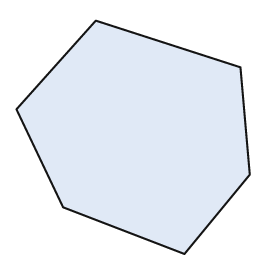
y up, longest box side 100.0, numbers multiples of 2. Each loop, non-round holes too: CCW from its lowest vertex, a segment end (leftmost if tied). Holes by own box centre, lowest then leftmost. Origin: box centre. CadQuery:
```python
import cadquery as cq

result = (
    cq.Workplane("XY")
    .moveTo(22.0, -50.0)
    .lineTo(50.0, -16.0)
    .lineTo(46.0, 30.0)
    .lineTo(-16.0, 50.0)
    .lineTo(-50.0, 12.0)
    .lineTo(-30.0, -30.0)
    .close()
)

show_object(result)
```